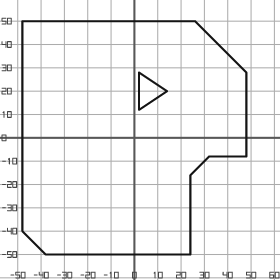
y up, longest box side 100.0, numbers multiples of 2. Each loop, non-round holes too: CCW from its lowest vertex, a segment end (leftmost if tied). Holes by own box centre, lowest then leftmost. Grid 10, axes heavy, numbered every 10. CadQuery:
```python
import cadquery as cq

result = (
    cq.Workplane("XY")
    .moveTo(-38.0, -50.0)
    .lineTo(24.0, -50.0)
    .lineTo(24.0, -16.0)
    .lineTo(32.0, -8.0)
    .lineTo(48.0, -8.0)
    .lineTo(48.0, 28.0)
    .lineTo(26.0, 50.0)
    .lineTo(-48.0, 50.0)
    .lineTo(-48.0, -40.0)
    .close()
    .moveTo(2.0, 12.0)
    .lineTo(14.0, 20.0)
    .lineTo(2.0, 28.0)
    .close()
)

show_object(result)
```